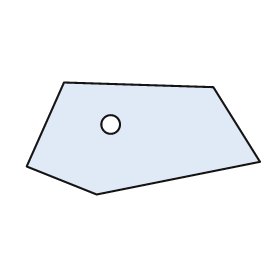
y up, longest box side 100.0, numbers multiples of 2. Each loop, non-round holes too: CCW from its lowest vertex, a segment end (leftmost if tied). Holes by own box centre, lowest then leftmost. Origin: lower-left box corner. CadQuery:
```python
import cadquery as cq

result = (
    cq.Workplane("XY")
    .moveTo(30.0, 0.0)
    .lineTo(100.0, 14.0)
    .lineTo(80.0, 46.0)
    .lineTo(16.0, 48.0)
    .lineTo(0.0, 12.0)
    .close()
    .moveTo(36.0, 30.0)
    .circle(4.0)
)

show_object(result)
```